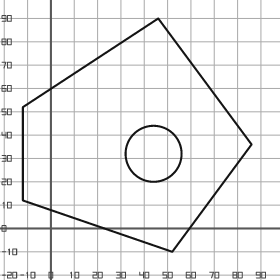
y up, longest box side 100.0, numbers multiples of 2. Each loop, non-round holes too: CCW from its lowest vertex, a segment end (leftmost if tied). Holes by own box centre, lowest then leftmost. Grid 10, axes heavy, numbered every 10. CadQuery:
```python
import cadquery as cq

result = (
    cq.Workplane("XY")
    .moveTo(52.0, -10.0)
    .lineTo(86.0, 36.0)
    .lineTo(46.0, 90.0)
    .lineTo(-12.0, 52.0)
    .lineTo(-12.0, 12.0)
    .close()
    .moveTo(44.0, 32.0)
    .circle(12.0)
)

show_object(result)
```